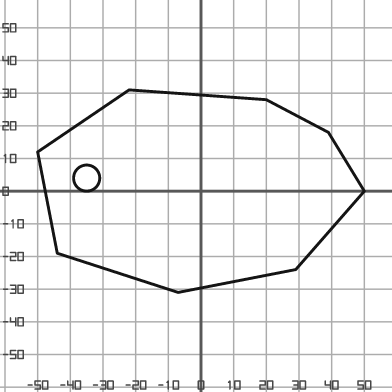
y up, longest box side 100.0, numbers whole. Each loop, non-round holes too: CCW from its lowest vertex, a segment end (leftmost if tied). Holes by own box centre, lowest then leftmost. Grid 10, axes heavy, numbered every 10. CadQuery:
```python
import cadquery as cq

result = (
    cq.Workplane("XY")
    .moveTo(-7.0, -31.0)
    .lineTo(29.0, -24.0)
    .lineTo(50.0, 0.0)
    .lineTo(39.0, 18.0)
    .lineTo(20.0, 28.0)
    .lineTo(-22.0, 31.0)
    .lineTo(-50.0, 12.0)
    .lineTo(-44.0, -19.0)
    .close()
    .moveTo(-35.0, 4.0)
    .circle(4.0)
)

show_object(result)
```